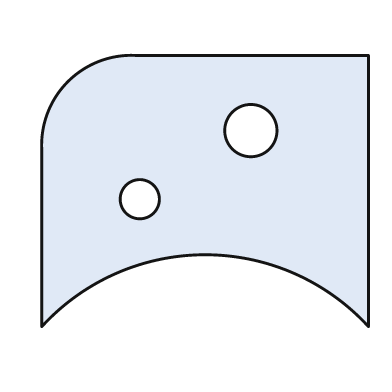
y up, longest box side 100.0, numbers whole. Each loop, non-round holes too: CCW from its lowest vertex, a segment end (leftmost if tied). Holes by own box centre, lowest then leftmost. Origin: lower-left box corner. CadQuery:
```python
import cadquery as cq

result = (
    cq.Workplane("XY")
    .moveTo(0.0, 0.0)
    .threePointArc((50.0, 22.0), (100.0, 0.0))
    .lineTo(100.0, 83.0)
    .lineTo(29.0, 83.0)
    .threePointArc((8.0, 75.0), (0.0, 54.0))
    .close()
    .moveTo(30.0, 39.0)
    .circle(6.0)
    .moveTo(64.0, 60.0)
    .circle(8.0)
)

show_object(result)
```